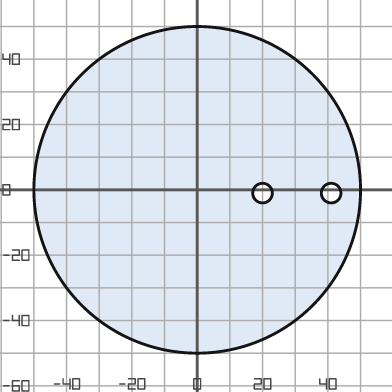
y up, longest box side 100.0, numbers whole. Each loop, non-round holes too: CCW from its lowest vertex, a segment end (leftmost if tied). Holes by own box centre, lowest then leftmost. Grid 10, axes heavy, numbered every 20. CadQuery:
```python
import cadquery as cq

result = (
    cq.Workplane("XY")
    .moveTo(0.0, 0.0)
    .circle(50.0)
    .moveTo(20.0, -1.0)
    .circle(3.0)
    .moveTo(41.0, -1.0)
    .circle(3.0)
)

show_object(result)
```